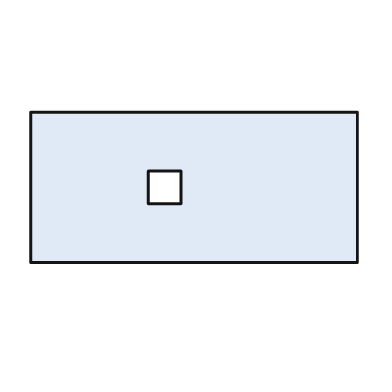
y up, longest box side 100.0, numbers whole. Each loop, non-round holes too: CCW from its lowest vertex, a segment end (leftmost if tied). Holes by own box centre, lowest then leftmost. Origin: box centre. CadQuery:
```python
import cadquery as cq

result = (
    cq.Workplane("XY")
    .moveTo(-50.0, -23.0)
    .lineTo(50.0, -23.0)
    .lineTo(50.0, 23.0)
    .lineTo(-50.0, 23.0)
    .close()
    .moveTo(-14.0, -5.0)
    .lineTo(-4.0, -5.0)
    .lineTo(-4.0, 5.0)
    .lineTo(-14.0, 5.0)
    .close()
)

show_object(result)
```